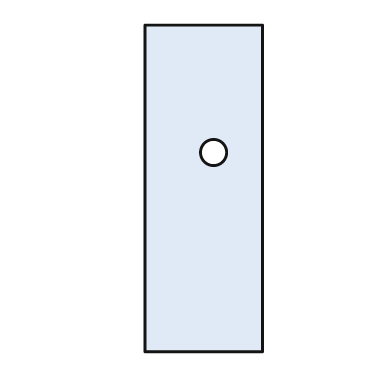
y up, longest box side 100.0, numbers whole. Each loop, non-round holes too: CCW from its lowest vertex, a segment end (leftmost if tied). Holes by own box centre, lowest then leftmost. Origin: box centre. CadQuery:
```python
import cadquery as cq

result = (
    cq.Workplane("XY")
    .moveTo(-18.0, -50.0)
    .lineTo(18.0, -50.0)
    .lineTo(18.0, 50.0)
    .lineTo(-18.0, 50.0)
    .close()
    .moveTo(3.0, 11.0)
    .circle(4.0)
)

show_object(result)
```